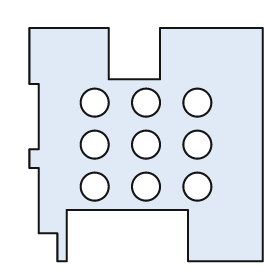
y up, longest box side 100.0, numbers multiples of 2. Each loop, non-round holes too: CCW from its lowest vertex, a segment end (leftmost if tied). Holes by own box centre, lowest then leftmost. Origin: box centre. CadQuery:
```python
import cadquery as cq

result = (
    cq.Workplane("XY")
    .moveTo(-38.0, -50.0)
    .lineTo(-34.0, -50.0)
    .lineTo(-34.0, -28.0)
    .lineTo(18.0, -28.0)
    .lineTo(18.0, -50.0)
    .lineTo(50.0, -50.0)
    .lineTo(50.0, 50.0)
    .lineTo(6.0, 50.0)
    .lineTo(6.0, 28.0)
    .lineTo(-16.0, 28.0)
    .lineTo(-16.0, 50.0)
    .lineTo(-50.0, 50.0)
    .lineTo(-50.0, 26.0)
    .lineTo(-46.0, 26.0)
    .lineTo(-46.0, -2.0)
    .lineTo(-50.0, -2.0)
    .lineTo(-50.0, -10.0)
    .lineTo(-46.0, -10.0)
    .lineTo(-46.0, -38.0)
    .lineTo(-38.0, -38.0)
    .close()
    .moveTo(-22.0, -18.0)
    .circle(6.0)
    .moveTo(0.0, -18.0)
    .circle(6.0)
    .moveTo(22.0, -18.0)
    .circle(6.0)
    .moveTo(-22.0, 0.0)
    .circle(6.0)
    .moveTo(0.0, 0.0)
    .circle(6.0)
    .moveTo(22.0, 0.0)
    .circle(6.0)
    .moveTo(-22.0, 18.0)
    .circle(6.0)
    .moveTo(0.0, 18.0)
    .circle(6.0)
    .moveTo(22.0, 18.0)
    .circle(6.0)
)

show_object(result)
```